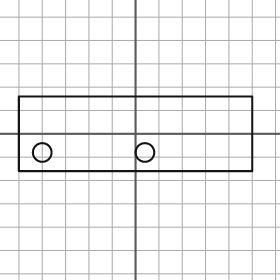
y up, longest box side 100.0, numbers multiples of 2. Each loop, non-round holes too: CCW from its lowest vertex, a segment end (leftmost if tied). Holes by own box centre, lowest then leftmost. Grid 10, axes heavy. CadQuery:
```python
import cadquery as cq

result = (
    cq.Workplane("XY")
    .moveTo(-50.0, -16.0)
    .lineTo(50.0, -16.0)
    .lineTo(50.0, 16.0)
    .lineTo(-50.0, 16.0)
    .close()
    .moveTo(-40.0, -8.0)
    .circle(4.0)
    .moveTo(4.0, -8.0)
    .circle(4.0)
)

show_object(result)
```